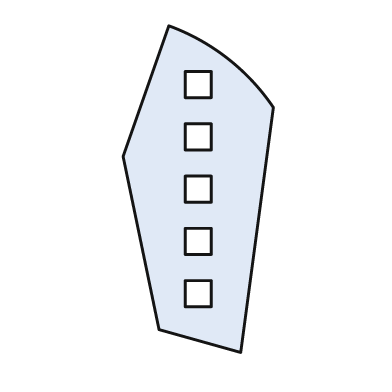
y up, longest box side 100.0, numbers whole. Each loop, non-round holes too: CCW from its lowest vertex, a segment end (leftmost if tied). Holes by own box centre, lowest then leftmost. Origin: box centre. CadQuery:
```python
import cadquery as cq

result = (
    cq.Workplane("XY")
    .moveTo(13.0, -50.0)
    .lineTo(23.0, 25.0)
    .threePointArc((9.0, 40.0), (-9.0, 50.0))
    .lineTo(-23.0, 10.0)
    .lineTo(-12.0, -43.0)
    .close()
    .moveTo(-4.0, -36.0)
    .lineTo(4.0, -36.0)
    .lineTo(4.0, -28.0)
    .lineTo(-4.0, -28.0)
    .close()
    .moveTo(-4.0, -20.0)
    .lineTo(4.0, -20.0)
    .lineTo(4.0, -12.0)
    .lineTo(-4.0, -12.0)
    .close()
    .moveTo(-4.0, -4.0)
    .lineTo(4.0, -4.0)
    .lineTo(4.0, 4.0)
    .lineTo(-4.0, 4.0)
    .close()
    .moveTo(-4.0, 12.0)
    .lineTo(4.0, 12.0)
    .lineTo(4.0, 20.0)
    .lineTo(-4.0, 20.0)
    .close()
    .moveTo(-4.0, 28.0)
    .lineTo(4.0, 28.0)
    .lineTo(4.0, 36.0)
    .lineTo(-4.0, 36.0)
    .close()
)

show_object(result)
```